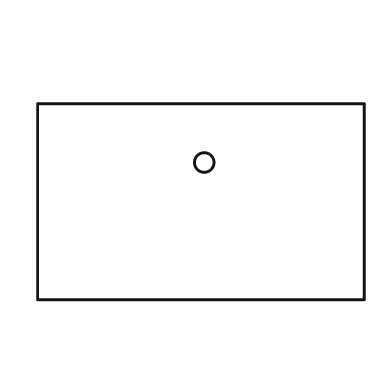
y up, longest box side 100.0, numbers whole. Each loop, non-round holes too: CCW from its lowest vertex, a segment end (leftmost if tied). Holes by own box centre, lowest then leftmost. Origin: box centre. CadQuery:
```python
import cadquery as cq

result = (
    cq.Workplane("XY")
    .moveTo(-50.0, -30.0)
    .lineTo(50.0, -30.0)
    .lineTo(50.0, 30.0)
    .lineTo(-50.0, 30.0)
    .close()
    .moveTo(1.0, 12.0)
    .circle(3.0)
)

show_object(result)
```